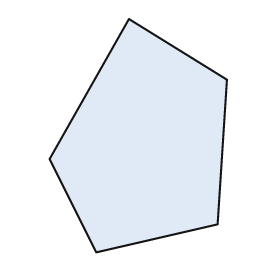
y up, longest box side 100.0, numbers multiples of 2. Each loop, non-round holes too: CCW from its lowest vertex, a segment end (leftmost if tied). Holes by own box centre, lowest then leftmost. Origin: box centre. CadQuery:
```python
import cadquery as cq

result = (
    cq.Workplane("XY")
    .moveTo(-18.0, -50.0)
    .lineTo(34.0, -38.0)
    .lineTo(38.0, 24.0)
    .lineTo(-4.0, 50.0)
    .lineTo(-38.0, -10.0)
    .close()
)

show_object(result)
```